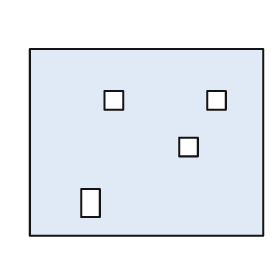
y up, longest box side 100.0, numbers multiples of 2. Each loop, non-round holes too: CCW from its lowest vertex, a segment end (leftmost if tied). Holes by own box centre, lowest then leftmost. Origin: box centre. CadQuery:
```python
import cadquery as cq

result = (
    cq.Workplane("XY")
    .moveTo(-50.0, -40.0)
    .lineTo(50.0, -40.0)
    .lineTo(50.0, 40.0)
    .lineTo(-50.0, 40.0)
    .close()
    .moveTo(-28.0, -32.0)
    .lineTo(-20.0, -32.0)
    .lineTo(-20.0, -20.0)
    .lineTo(-28.0, -20.0)
    .close()
    .moveTo(14.0, -6.0)
    .lineTo(22.0, -6.0)
    .lineTo(22.0, 2.0)
    .lineTo(14.0, 2.0)
    .close()
    .moveTo(-18.0, 14.0)
    .lineTo(-10.0, 14.0)
    .lineTo(-10.0, 22.0)
    .lineTo(-18.0, 22.0)
    .close()
    .moveTo(26.0, 14.0)
    .lineTo(34.0, 14.0)
    .lineTo(34.0, 22.0)
    .lineTo(26.0, 22.0)
    .close()
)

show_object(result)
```